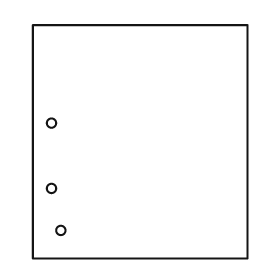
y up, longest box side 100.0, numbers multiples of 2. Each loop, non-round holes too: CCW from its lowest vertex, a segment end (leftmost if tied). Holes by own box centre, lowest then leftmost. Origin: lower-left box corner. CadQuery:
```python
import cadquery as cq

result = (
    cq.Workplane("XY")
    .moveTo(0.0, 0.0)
    .lineTo(92.0, 0.0)
    .lineTo(92.0, 100.0)
    .lineTo(0.0, 100.0)
    .close()
    .moveTo(12.0, 12.0)
    .circle(2.0)
    .moveTo(8.0, 30.0)
    .circle(2.0)
    .moveTo(8.0, 58.0)
    .circle(2.0)
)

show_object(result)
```